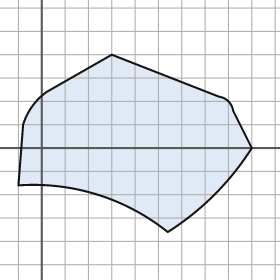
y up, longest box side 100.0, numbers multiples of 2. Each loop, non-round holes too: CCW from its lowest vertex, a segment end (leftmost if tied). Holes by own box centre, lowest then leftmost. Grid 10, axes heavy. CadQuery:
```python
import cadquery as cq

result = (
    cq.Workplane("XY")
    .moveTo(54.0, -36.0)
    .threePointArc((74.0, -20.0), (90.0, 0.0))
    .lineTo(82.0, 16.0)
    .threePointArc((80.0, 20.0), (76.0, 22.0))
    .lineTo(30.0, 40.0)
    .lineTo(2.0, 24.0)
    .threePointArc((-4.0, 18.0), (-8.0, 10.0))
    .lineTo(-10.0, -16.0)
    .threePointArc((24.0, -20.0), (54.0, -36.0))
    .close()
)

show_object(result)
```